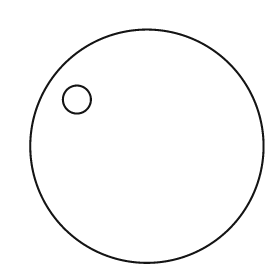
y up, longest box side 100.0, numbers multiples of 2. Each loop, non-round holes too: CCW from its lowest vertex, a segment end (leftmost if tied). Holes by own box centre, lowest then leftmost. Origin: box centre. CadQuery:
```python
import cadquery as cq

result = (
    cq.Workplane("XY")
    .moveTo(0.0, 0.0)
    .circle(50.0)
    .moveTo(-30.0, 20.0)
    .circle(6.0)
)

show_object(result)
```